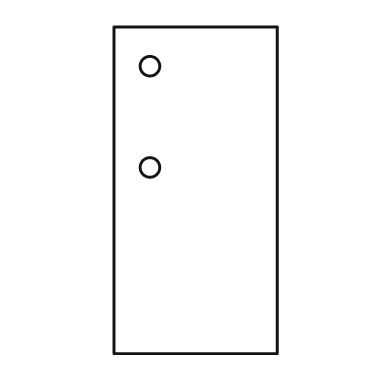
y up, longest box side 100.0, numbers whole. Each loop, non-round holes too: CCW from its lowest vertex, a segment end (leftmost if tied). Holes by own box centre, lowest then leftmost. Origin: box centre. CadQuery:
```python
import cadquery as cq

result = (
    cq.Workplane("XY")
    .moveTo(-25.0, -50.0)
    .lineTo(25.0, -50.0)
    .lineTo(25.0, 50.0)
    .lineTo(-25.0, 50.0)
    .close()
    .moveTo(-14.0, 7.0)
    .circle(3.0)
    .moveTo(-14.0, 38.0)
    .circle(3.0)
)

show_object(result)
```